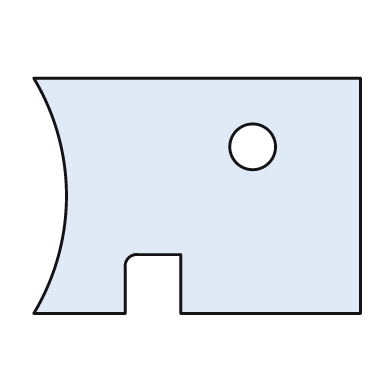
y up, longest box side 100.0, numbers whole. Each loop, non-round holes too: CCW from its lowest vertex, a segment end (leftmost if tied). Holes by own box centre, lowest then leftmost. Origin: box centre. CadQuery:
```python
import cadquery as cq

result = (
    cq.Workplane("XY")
    .moveTo(-50.0, -36.0)
    .lineTo(-22.0, -36.0)
    .lineTo(-22.0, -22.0)
    .threePointArc((-21.0, -19.0), (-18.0, -18.0))
    .lineTo(-5.0, -18.0)
    .lineTo(-5.0, -36.0)
    .lineTo(50.0, -36.0)
    .lineTo(50.0, 36.0)
    .lineTo(-50.0, 36.0)
    .threePointArc((-40.0, 0.0), (-50.0, -36.0))
    .close()
    .moveTo(17.0, 15.0)
    .circle(7.0)
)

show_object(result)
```